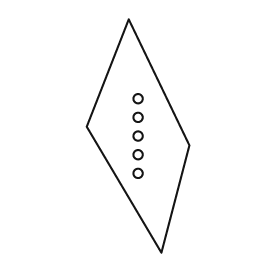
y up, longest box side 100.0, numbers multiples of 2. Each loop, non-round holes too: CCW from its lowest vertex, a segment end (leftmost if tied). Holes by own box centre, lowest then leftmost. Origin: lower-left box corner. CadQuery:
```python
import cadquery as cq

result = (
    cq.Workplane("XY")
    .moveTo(32.0, 0.0)
    .lineTo(44.0, 46.0)
    .lineTo(18.0, 100.0)
    .lineTo(0.0, 54.0)
    .close()
    .moveTo(22.0, 34.0)
    .circle(2.0)
    .moveTo(22.0, 42.0)
    .circle(2.0)
    .moveTo(22.0, 50.0)
    .circle(2.0)
    .moveTo(22.0, 58.0)
    .circle(2.0)
    .moveTo(22.0, 66.0)
    .circle(2.0)
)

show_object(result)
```